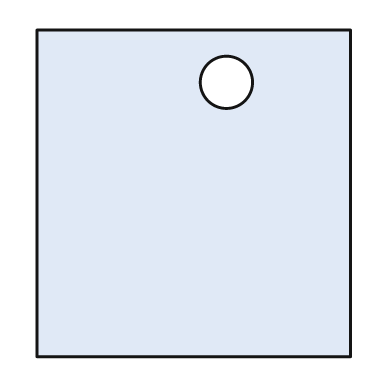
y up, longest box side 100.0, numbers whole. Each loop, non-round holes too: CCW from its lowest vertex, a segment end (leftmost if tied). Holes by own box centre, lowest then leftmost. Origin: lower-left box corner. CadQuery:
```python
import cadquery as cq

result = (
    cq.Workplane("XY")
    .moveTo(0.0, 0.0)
    .lineTo(96.0, 0.0)
    .lineTo(96.0, 100.0)
    .lineTo(0.0, 100.0)
    .close()
    .moveTo(58.0, 84.0)
    .circle(8.0)
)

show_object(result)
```